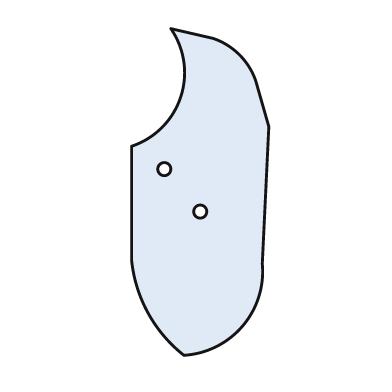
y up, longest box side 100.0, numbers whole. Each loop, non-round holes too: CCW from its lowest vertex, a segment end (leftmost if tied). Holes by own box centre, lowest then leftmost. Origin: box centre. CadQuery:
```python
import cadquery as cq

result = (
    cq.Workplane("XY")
    .moveTo(-5.0, -50.0)
    .threePointArc((13.0, -41.0), (19.0, -22.0))
    .lineTo(21.0, 20.0)
    .lineTo(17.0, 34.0)
    .threePointArc((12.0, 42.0), (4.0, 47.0))
    .lineTo(-9.0, 50.0)
    .threePointArc((-6.0, 29.0), (-21.0, 14.0))
    .lineTo(-21.0, -21.0)
    .threePointArc((-16.0, -37.0), (-5.0, -50.0))
    .close()
    .moveTo(0.0, -6.0)
    .circle(2.0)
    .moveTo(-11.0, 7.0)
    .circle(2.0)
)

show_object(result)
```